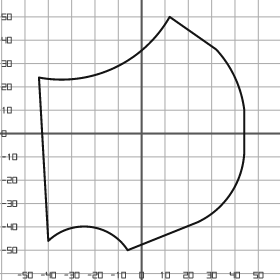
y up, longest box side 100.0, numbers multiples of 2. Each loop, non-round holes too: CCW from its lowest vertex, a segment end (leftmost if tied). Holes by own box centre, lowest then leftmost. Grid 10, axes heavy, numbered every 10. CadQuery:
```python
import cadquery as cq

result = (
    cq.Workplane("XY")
    .moveTo(-6.0, -50.0)
    .lineTo(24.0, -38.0)
    .threePointArc((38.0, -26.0), (44.0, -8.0))
    .lineTo(44.0, 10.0)
    .threePointArc((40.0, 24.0), (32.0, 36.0))
    .lineTo(12.0, 50.0)
    .threePointArc((-12.0, 28.0), (-44.0, 24.0))
    .lineTo(-40.0, -46.0)
    .threePointArc((-22.0, -40.0), (-6.0, -50.0))
    .close()
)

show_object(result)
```